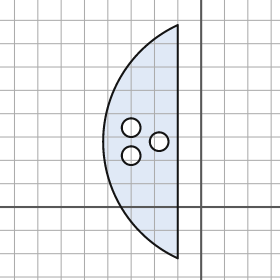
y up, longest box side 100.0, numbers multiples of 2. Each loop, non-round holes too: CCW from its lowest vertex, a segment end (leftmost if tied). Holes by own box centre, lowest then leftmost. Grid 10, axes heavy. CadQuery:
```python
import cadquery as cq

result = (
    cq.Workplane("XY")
    .moveTo(-10.0, -22.0)
    .lineTo(-10.0, 78.0)
    .threePointArc((-42.0, 28.0), (-10.0, -22.0))
    .close()
    .moveTo(-30.0, 22.0)
    .circle(4.0)
    .moveTo(-18.0, 28.0)
    .circle(4.0)
    .moveTo(-30.0, 34.0)
    .circle(4.0)
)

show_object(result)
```